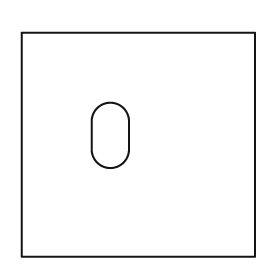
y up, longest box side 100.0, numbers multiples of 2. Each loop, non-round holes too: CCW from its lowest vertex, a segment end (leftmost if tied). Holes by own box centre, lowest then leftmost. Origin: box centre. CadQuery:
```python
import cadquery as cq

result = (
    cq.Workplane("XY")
    .moveTo(-50.0, -48.0)
    .lineTo(50.0, -48.0)
    .lineTo(50.0, 48.0)
    .lineTo(-50.0, 48.0)
    .close()
    .moveTo(-20.0, -2.0)
    .threePointArc((-12.0, -10.0), (-4.0, -2.0))
    .lineTo(-4.0, 10.0)
    .threePointArc((-12.0, 18.0), (-20.0, 10.0))
    .close()
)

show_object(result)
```